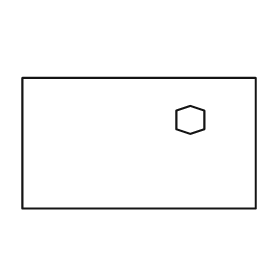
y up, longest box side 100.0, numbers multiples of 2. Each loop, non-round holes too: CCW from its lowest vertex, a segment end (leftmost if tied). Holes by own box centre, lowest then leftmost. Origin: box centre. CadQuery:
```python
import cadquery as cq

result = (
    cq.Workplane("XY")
    .moveTo(-50.0, -28.0)
    .lineTo(50.0, -28.0)
    .lineTo(50.0, 28.0)
    .lineTo(-50.0, 28.0)
    .close()
    .moveTo(22.0, 4.0)
    .lineTo(28.0, 6.0)
    .lineTo(28.0, 14.0)
    .lineTo(22.0, 16.0)
    .lineTo(16.0, 14.0)
    .lineTo(16.0, 6.0)
    .close()
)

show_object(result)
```